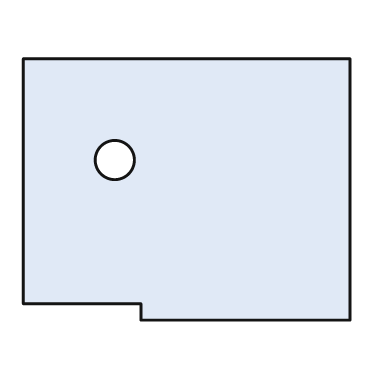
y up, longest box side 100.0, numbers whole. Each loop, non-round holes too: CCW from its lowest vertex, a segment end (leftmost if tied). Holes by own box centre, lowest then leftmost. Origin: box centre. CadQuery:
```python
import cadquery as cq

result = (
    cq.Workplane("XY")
    .moveTo(-14.0, -40.0)
    .lineTo(50.0, -40.0)
    .lineTo(50.0, 40.0)
    .lineTo(-50.0, 40.0)
    .lineTo(-50.0, -35.0)
    .lineTo(-14.0, -35.0)
    .close()
    .moveTo(-22.0, 9.0)
    .circle(6.0)
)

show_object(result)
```